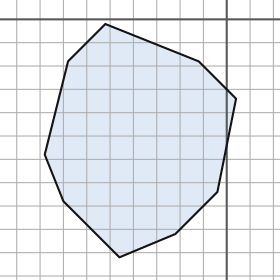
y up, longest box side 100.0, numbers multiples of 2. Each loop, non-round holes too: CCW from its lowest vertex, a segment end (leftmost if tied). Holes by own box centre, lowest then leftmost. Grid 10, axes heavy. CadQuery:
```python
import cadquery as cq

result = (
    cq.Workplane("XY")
    .moveTo(-46.0, -102.0)
    .lineTo(-22.0, -92.0)
    .lineTo(-4.0, -74.0)
    .lineTo(4.0, -34.0)
    .lineTo(-12.0, -18.0)
    .lineTo(-52.0, -2.0)
    .lineTo(-68.0, -18.0)
    .lineTo(-78.0, -58.0)
    .lineTo(-70.0, -78.0)
    .close()
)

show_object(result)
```